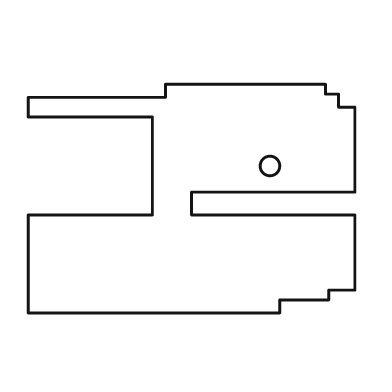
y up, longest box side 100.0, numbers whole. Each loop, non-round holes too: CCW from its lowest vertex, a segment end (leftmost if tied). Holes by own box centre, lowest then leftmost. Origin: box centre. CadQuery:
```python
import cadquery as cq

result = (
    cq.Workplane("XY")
    .moveTo(-50.0, -35.0)
    .lineTo(27.0, -35.0)
    .lineTo(27.0, -31.0)
    .lineTo(42.0, -31.0)
    .lineTo(42.0, -28.0)
    .lineTo(50.0, -28.0)
    .lineTo(50.0, -5.0)
    .lineTo(0.0, -5.0)
    .lineTo(0.0, 2.0)
    .lineTo(50.0, 2.0)
    .lineTo(50.0, 28.0)
    .lineTo(45.0, 28.0)
    .lineTo(45.0, 32.0)
    .lineTo(41.0, 32.0)
    .lineTo(41.0, 35.0)
    .lineTo(-8.0, 35.0)
    .lineTo(-8.0, 31.0)
    .lineTo(-50.0, 31.0)
    .lineTo(-50.0, 25.0)
    .lineTo(-12.0, 25.0)
    .lineTo(-12.0, -5.0)
    .lineTo(-50.0, -5.0)
    .close()
    .moveTo(24.0, 10.0)
    .circle(3.0)
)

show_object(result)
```